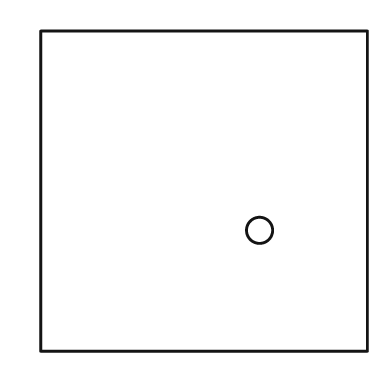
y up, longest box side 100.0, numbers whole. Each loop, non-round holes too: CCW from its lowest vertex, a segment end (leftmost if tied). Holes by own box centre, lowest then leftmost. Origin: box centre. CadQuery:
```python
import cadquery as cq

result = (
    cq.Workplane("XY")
    .moveTo(-50.0, -49.0)
    .lineTo(50.0, -49.0)
    .lineTo(50.0, 49.0)
    .lineTo(-50.0, 49.0)
    .close()
    .moveTo(17.0, -12.0)
    .circle(4.0)
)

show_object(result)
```